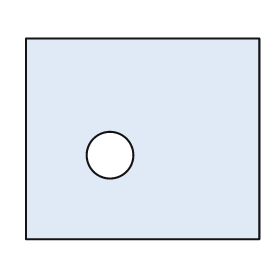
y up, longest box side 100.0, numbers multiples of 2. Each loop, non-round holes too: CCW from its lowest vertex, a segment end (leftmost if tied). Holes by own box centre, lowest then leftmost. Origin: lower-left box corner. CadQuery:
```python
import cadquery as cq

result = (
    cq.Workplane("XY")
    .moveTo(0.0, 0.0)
    .lineTo(100.0, 0.0)
    .lineTo(100.0, 86.0)
    .lineTo(0.0, 86.0)
    .close()
    .moveTo(36.0, 36.0)
    .circle(10.0)
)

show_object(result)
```